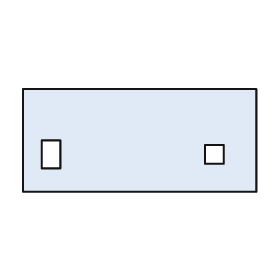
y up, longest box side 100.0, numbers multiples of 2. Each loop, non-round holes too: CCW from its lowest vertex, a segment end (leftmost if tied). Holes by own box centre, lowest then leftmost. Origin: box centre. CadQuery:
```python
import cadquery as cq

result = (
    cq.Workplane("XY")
    .moveTo(-50.0, -22.0)
    .lineTo(50.0, -22.0)
    .lineTo(50.0, 22.0)
    .lineTo(-50.0, 22.0)
    .close()
    .moveTo(-42.0, -12.0)
    .lineTo(-34.0, -12.0)
    .lineTo(-34.0, 0.0)
    .lineTo(-42.0, 0.0)
    .close()
    .moveTo(28.0, -10.0)
    .lineTo(36.0, -10.0)
    .lineTo(36.0, -2.0)
    .lineTo(28.0, -2.0)
    .close()
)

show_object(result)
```